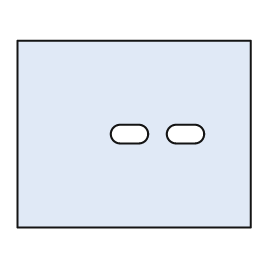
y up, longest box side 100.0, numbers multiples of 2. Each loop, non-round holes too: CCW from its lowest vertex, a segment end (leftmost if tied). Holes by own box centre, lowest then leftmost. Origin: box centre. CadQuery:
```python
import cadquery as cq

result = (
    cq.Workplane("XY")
    .moveTo(-50.0, -40.0)
    .lineTo(50.0, -40.0)
    .lineTo(50.0, 40.0)
    .lineTo(-50.0, 40.0)
    .close()
    .moveTo(-6.0, -4.0)
    .lineTo(2.0, -4.0)
    .threePointArc((6.0, 0.0), (2.0, 4.0))
    .lineTo(-6.0, 4.0)
    .threePointArc((-10.0, 0.0), (-6.0, -4.0))
    .close()
    .moveTo(18.0, -4.0)
    .lineTo(26.0, -4.0)
    .threePointArc((30.0, 0.0), (26.0, 4.0))
    .lineTo(18.0, 4.0)
    .threePointArc((14.0, 0.0), (18.0, -4.0))
    .close()
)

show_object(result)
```